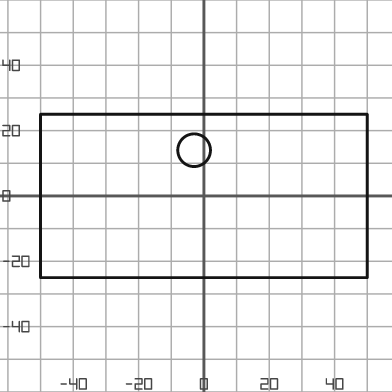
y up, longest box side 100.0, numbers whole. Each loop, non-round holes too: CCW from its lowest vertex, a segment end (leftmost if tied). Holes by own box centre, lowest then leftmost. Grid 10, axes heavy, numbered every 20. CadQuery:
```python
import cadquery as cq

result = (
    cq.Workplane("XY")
    .moveTo(-50.0, -25.0)
    .lineTo(50.0, -25.0)
    .lineTo(50.0, 25.0)
    .lineTo(-50.0, 25.0)
    .close()
    .moveTo(-3.0, 14.0)
    .circle(5.0)
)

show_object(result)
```